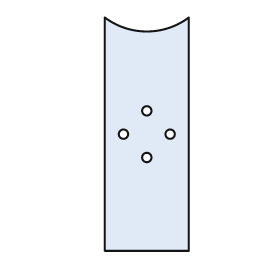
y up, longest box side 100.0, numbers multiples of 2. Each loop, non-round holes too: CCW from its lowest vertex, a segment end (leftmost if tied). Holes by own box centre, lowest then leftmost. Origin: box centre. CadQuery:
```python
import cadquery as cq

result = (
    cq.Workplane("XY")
    .moveTo(-18.0, -50.0)
    .lineTo(18.0, -50.0)
    .lineTo(18.0, 50.0)
    .threePointArc((0.0, 44.0), (-18.0, 50.0))
    .close()
    .moveTo(0.0, -10.0)
    .circle(2.0)
    .moveTo(-10.0, 0.0)
    .circle(2.0)
    .moveTo(10.0, 0.0)
    .circle(2.0)
    .moveTo(0.0, 10.0)
    .circle(2.0)
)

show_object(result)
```